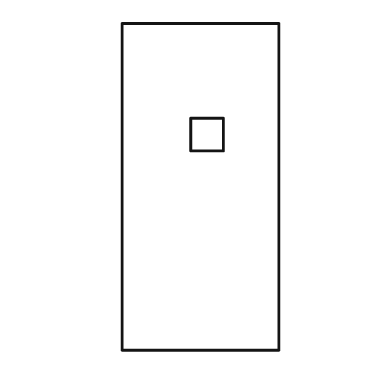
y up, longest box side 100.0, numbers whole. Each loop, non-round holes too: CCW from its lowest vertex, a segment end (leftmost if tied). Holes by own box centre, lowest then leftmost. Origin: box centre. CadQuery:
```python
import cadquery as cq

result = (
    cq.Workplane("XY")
    .moveTo(-24.0, -50.0)
    .lineTo(24.0, -50.0)
    .lineTo(24.0, 50.0)
    .lineTo(-24.0, 50.0)
    .close()
    .moveTo(-3.0, 11.0)
    .lineTo(7.0, 11.0)
    .lineTo(7.0, 21.0)
    .lineTo(-3.0, 21.0)
    .close()
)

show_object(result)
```